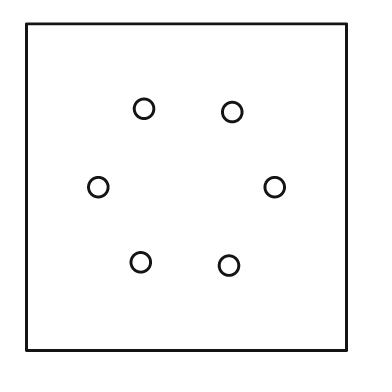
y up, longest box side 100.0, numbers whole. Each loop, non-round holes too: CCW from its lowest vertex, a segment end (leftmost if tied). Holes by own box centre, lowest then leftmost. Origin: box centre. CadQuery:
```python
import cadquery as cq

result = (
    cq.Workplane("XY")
    .moveTo(-49.0, -50.0)
    .lineTo(49.0, -50.0)
    .lineTo(49.0, 50.0)
    .lineTo(-49.0, 50.0)
    .close()
    .moveTo(13.0, -24.0)
    .circle(3.0)
    .moveTo(-14.0, -23.0)
    .circle(3.0)
    .moveTo(-27.0, 0.0)
    .circle(3.0)
    .moveTo(27.0, 0.0)
    .circle(3.0)
    .moveTo(14.0, 23.0)
    .circle(3.0)
    .moveTo(-13.0, 24.0)
    .circle(3.0)
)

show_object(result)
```